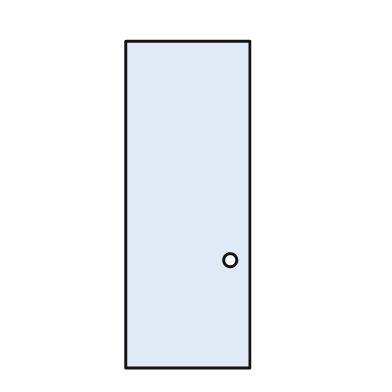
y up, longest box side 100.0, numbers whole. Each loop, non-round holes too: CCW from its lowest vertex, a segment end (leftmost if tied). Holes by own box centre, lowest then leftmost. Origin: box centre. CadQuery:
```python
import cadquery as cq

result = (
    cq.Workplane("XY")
    .moveTo(-19.0, -50.0)
    .lineTo(19.0, -50.0)
    .lineTo(19.0, 50.0)
    .lineTo(-19.0, 50.0)
    .close()
    .moveTo(13.0, -17.0)
    .circle(2.0)
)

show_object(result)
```